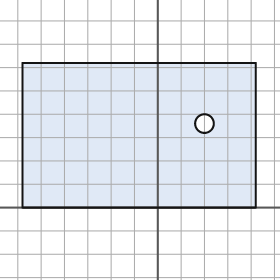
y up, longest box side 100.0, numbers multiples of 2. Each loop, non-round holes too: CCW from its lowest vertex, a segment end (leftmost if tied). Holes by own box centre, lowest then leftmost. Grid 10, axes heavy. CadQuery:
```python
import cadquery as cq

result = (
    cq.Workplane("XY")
    .moveTo(-58.0, 0.0)
    .lineTo(42.0, 0.0)
    .lineTo(42.0, 62.0)
    .lineTo(-58.0, 62.0)
    .close()
    .moveTo(20.0, 36.0)
    .circle(4.0)
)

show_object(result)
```